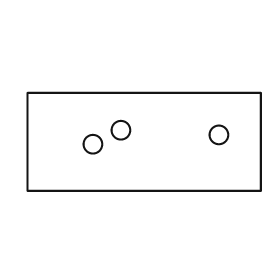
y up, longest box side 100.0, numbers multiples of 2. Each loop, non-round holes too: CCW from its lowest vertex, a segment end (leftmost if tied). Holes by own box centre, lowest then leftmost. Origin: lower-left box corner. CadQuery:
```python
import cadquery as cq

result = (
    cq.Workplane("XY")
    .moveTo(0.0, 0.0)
    .lineTo(100.0, 0.0)
    .lineTo(100.0, 42.0)
    .lineTo(0.0, 42.0)
    .close()
    .moveTo(28.0, 20.0)
    .circle(4.0)
    .moveTo(82.0, 24.0)
    .circle(4.0)
    .moveTo(40.0, 26.0)
    .circle(4.0)
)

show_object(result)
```